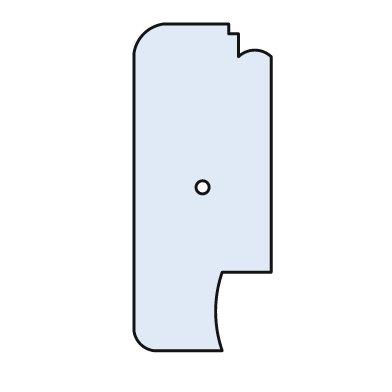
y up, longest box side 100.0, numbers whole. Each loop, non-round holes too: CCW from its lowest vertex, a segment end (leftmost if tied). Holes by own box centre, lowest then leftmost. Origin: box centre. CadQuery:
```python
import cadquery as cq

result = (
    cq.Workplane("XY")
    .moveTo(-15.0, -50.0)
    .lineTo(6.0, -50.0)
    .threePointArc((4.0, -38.0), (6.0, -26.0))
    .lineTo(21.0, -26.0)
    .lineTo(21.0, 40.0)
    .threePointArc((16.0, 42.0), (11.0, 40.0))
    .lineTo(11.0, 47.0)
    .lineTo(8.0, 47.0)
    .lineTo(8.0, 50.0)
    .lineTo(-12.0, 50.0)
    .threePointArc((-18.0, 47.0), (-21.0, 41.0))
    .lineTo(-21.0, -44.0)
    .threePointArc((-19.0, -48.0), (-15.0, -50.0))
    .close()
    .moveTo(0.0, 0.0)
    .circle(2.0)
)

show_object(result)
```